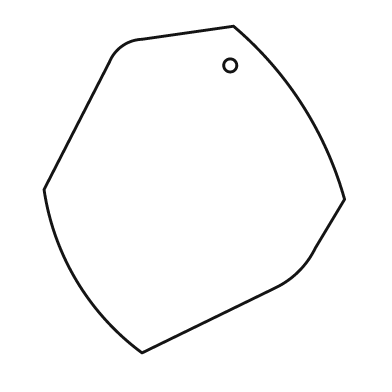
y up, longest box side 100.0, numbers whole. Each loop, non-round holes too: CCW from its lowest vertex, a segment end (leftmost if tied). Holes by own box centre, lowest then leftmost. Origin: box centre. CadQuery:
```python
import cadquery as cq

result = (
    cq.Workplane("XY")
    .moveTo(-16.0, -50.0)
    .lineTo(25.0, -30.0)
    .threePointArc((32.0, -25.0), (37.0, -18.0))
    .lineTo(46.0, -3.0)
    .threePointArc((33.0, 26.0), (12.0, 50.0))
    .lineTo(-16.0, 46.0)
    .threePointArc((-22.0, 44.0), (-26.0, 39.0))
    .lineTo(-46.0, 0.0)
    .threePointArc((-36.0, -28.0), (-16.0, -50.0))
    .close()
    .moveTo(11.0, 38.0)
    .circle(2.0)
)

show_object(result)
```